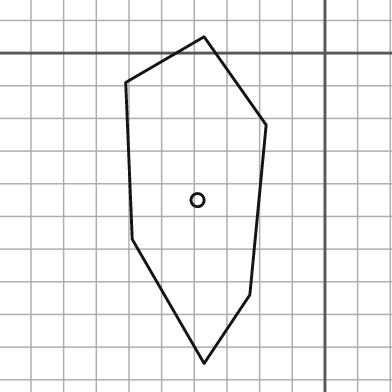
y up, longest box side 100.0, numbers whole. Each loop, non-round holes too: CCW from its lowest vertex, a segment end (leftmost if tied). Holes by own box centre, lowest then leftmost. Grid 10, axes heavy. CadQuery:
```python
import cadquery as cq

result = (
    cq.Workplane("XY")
    .moveTo(-37.0, -95.0)
    .lineTo(-23.0, -74.0)
    .lineTo(-18.0, -22.0)
    .lineTo(-37.0, 5.0)
    .lineTo(-61.0, -9.0)
    .lineTo(-59.0, -57.0)
    .close()
    .moveTo(-39.0, -45.0)
    .circle(2.0)
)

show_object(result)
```